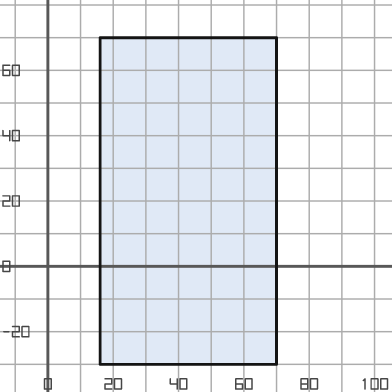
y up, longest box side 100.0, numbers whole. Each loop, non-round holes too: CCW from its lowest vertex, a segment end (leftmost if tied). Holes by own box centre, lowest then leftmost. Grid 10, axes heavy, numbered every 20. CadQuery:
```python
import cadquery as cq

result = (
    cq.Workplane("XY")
    .moveTo(16.0, -30.0)
    .lineTo(70.0, -30.0)
    .lineTo(70.0, 70.0)
    .lineTo(16.0, 70.0)
    .close()
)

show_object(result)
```